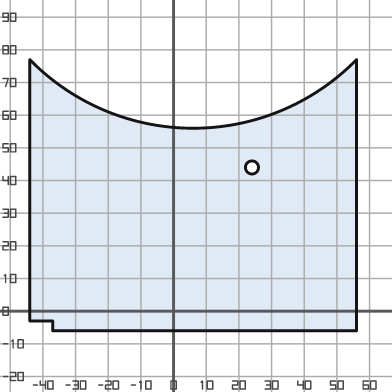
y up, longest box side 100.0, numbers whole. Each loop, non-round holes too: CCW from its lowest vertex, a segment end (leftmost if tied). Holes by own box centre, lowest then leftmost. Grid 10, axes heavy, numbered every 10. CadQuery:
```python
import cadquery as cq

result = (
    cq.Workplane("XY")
    .moveTo(-37.0, -6.0)
    .lineTo(56.0, -6.0)
    .lineTo(56.0, 77.0)
    .threePointArc((6.0, 56.0), (-44.0, 77.0))
    .lineTo(-44.0, -3.0)
    .lineTo(-37.0, -3.0)
    .close()
    .moveTo(24.0, 44.0)
    .circle(2.0)
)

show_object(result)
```